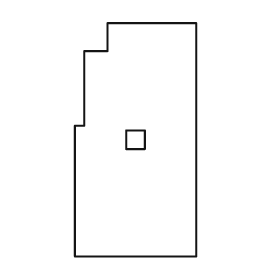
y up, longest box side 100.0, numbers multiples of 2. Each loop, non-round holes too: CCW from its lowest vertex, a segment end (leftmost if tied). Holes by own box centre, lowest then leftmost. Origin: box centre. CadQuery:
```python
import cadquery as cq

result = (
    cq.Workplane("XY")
    .moveTo(-26.0, -50.0)
    .lineTo(26.0, -50.0)
    .lineTo(26.0, 50.0)
    .lineTo(-12.0, 50.0)
    .lineTo(-12.0, 38.0)
    .lineTo(-22.0, 38.0)
    .lineTo(-22.0, 6.0)
    .lineTo(-26.0, 6.0)
    .close()
    .moveTo(-4.0, -4.0)
    .lineTo(4.0, -4.0)
    .lineTo(4.0, 4.0)
    .lineTo(-4.0, 4.0)
    .close()
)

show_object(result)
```